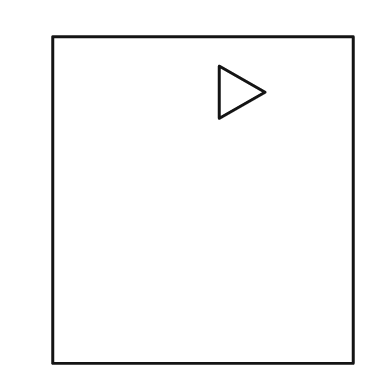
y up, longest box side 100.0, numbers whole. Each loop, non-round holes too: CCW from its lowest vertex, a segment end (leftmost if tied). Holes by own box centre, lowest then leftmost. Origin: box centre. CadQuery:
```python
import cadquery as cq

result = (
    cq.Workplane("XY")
    .moveTo(-46.0, -50.0)
    .lineTo(46.0, -50.0)
    .lineTo(46.0, 50.0)
    .lineTo(-46.0, 50.0)
    .close()
    .moveTo(5.0, 25.0)
    .lineTo(19.0, 33.0)
    .lineTo(5.0, 41.0)
    .close()
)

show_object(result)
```